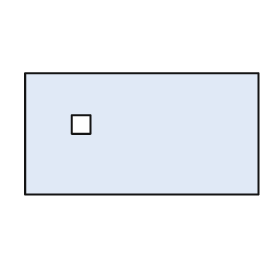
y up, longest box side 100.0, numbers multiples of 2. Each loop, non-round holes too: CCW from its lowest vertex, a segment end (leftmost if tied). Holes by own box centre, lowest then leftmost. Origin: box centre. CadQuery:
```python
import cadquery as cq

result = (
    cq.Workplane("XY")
    .moveTo(-50.0, -26.0)
    .lineTo(50.0, -26.0)
    .lineTo(50.0, 26.0)
    .lineTo(-50.0, 26.0)
    .close()
    .moveTo(-30.0, 0.0)
    .lineTo(-22.0, 0.0)
    .lineTo(-22.0, 8.0)
    .lineTo(-30.0, 8.0)
    .close()
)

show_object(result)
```